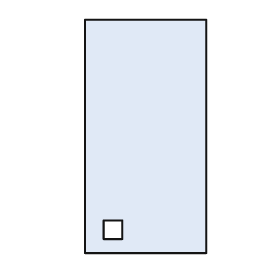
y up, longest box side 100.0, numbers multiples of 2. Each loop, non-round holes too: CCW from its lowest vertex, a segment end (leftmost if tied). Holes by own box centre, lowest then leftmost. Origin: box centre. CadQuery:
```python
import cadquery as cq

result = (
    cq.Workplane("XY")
    .moveTo(-26.0, -50.0)
    .lineTo(26.0, -50.0)
    .lineTo(26.0, 50.0)
    .lineTo(-26.0, 50.0)
    .close()
    .moveTo(-18.0, -44.0)
    .lineTo(-10.0, -44.0)
    .lineTo(-10.0, -36.0)
    .lineTo(-18.0, -36.0)
    .close()
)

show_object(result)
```